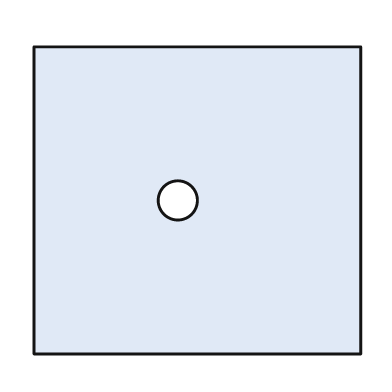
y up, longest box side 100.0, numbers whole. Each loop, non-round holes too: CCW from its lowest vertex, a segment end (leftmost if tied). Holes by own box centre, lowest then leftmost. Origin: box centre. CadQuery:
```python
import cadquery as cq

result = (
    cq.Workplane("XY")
    .moveTo(-50.0, -47.0)
    .lineTo(50.0, -47.0)
    .lineTo(50.0, 47.0)
    .lineTo(-50.0, 47.0)
    .close()
    .moveTo(-6.0, 0.0)
    .circle(6.0)
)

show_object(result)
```